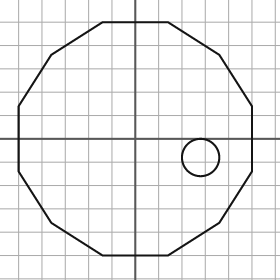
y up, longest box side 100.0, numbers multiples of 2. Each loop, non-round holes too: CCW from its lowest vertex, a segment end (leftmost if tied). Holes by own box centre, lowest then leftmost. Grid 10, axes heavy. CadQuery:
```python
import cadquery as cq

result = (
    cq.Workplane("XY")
    .moveTo(-14.0, -50.0)
    .lineTo(14.0, -50.0)
    .lineTo(36.0, -36.0)
    .lineTo(50.0, -14.0)
    .lineTo(50.0, 14.0)
    .lineTo(36.0, 36.0)
    .lineTo(14.0, 50.0)
    .lineTo(-14.0, 50.0)
    .lineTo(-36.0, 36.0)
    .lineTo(-50.0, 14.0)
    .lineTo(-50.0, -14.0)
    .lineTo(-36.0, -36.0)
    .close()
    .moveTo(28.0, -8.0)
    .circle(8.0)
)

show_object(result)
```